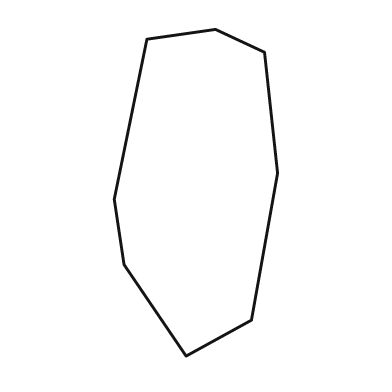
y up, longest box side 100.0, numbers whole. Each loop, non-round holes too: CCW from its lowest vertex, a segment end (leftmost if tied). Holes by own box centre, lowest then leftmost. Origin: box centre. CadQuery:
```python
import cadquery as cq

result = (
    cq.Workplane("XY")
    .moveTo(-3.0, -50.0)
    .lineTo(17.0, -39.0)
    .lineTo(25.0, 6.0)
    .lineTo(21.0, 43.0)
    .lineTo(6.0, 50.0)
    .lineTo(-15.0, 47.0)
    .lineTo(-25.0, -2.0)
    .lineTo(-22.0, -22.0)
    .close()
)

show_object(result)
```